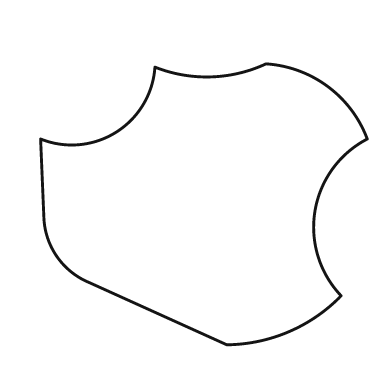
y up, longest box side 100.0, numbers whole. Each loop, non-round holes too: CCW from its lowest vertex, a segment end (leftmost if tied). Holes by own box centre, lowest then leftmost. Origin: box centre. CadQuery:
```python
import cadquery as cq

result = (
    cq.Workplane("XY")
    .moveTo(7.0, -43.0)
    .threePointArc((26.0, -39.0), (42.0, -28.0))
    .threePointArc((34.0, -2.0), (50.0, 20.0))
    .threePointArc((38.0, 36.0), (19.0, 43.0))
    .threePointArc((2.0, 39.0), (-15.0, 42.0))
    .threePointArc((-27.0, 22.0), (-50.0, 20.0))
    .lineTo(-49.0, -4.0)
    .threePointArc((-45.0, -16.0), (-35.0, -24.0))
    .close()
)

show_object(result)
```